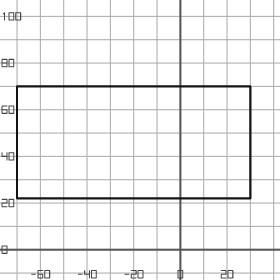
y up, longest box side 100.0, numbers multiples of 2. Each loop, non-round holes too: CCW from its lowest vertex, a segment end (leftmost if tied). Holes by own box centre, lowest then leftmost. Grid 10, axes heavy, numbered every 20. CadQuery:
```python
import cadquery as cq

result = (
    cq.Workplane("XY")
    .moveTo(-70.0, 22.0)
    .lineTo(30.0, 22.0)
    .lineTo(30.0, 70.0)
    .lineTo(-70.0, 70.0)
    .close()
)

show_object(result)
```